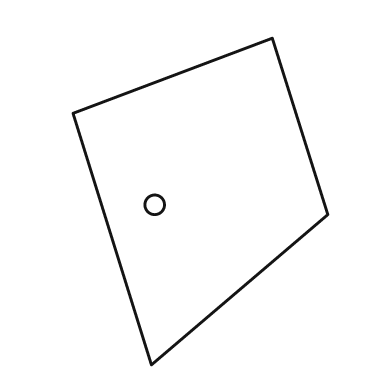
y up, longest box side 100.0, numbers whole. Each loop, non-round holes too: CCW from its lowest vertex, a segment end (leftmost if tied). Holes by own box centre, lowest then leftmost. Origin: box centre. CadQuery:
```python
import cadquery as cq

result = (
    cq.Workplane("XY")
    .moveTo(-15.0, -50.0)
    .lineTo(39.0, -4.0)
    .lineTo(22.0, 50.0)
    .lineTo(-39.0, 27.0)
    .close()
    .moveTo(-14.0, -1.0)
    .circle(3.0)
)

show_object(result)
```